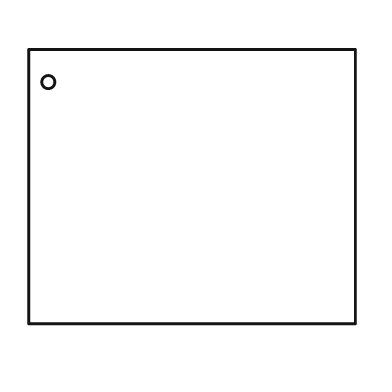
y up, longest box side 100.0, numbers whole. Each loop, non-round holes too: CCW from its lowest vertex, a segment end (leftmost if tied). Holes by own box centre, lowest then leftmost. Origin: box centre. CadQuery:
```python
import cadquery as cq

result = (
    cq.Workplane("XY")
    .moveTo(-50.0, -42.0)
    .lineTo(50.0, -42.0)
    .lineTo(50.0, 42.0)
    .lineTo(-50.0, 42.0)
    .close()
    .moveTo(-44.0, 32.0)
    .circle(2.0)
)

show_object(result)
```